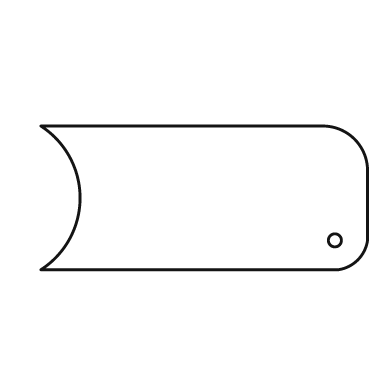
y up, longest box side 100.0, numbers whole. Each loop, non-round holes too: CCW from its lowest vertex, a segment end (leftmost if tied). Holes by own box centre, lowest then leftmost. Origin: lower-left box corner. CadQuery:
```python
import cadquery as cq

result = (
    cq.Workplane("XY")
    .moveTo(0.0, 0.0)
    .lineTo(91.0, 0.0)
    .threePointArc((97.0, 3.0), (100.0, 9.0))
    .lineTo(100.0, 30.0)
    .threePointArc((96.0, 40.0), (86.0, 44.0))
    .lineTo(0.0, 44.0)
    .threePointArc((12.0, 22.0), (0.0, 0.0))
    .close()
    .moveTo(90.0, 9.0)
    .circle(2.0)
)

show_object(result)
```